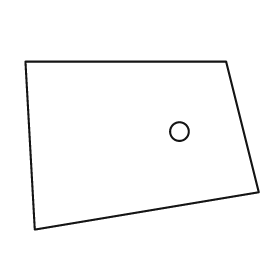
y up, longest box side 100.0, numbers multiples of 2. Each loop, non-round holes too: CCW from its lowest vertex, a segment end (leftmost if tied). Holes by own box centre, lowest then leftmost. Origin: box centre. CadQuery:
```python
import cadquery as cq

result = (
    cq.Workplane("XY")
    .moveTo(-46.0, -36.0)
    .lineTo(50.0, -20.0)
    .lineTo(36.0, 36.0)
    .lineTo(-50.0, 36.0)
    .close()
    .moveTo(16.0, 6.0)
    .circle(4.0)
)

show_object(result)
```